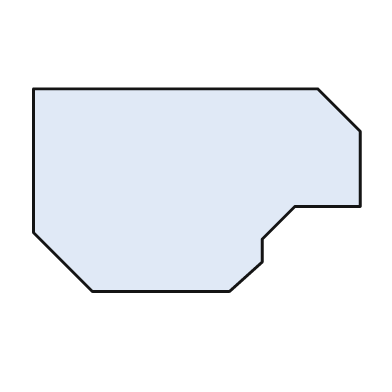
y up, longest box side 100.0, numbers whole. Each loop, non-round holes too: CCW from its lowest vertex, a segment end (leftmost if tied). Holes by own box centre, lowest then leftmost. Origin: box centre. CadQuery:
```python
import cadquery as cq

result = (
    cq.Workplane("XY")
    .moveTo(-32.0, -31.0)
    .lineTo(10.0, -31.0)
    .lineTo(20.0, -22.0)
    .lineTo(20.0, -15.0)
    .lineTo(30.0, -5.0)
    .lineTo(50.0, -5.0)
    .lineTo(50.0, 18.0)
    .lineTo(37.0, 31.0)
    .lineTo(-50.0, 31.0)
    .lineTo(-50.0, -13.0)
    .close()
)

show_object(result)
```